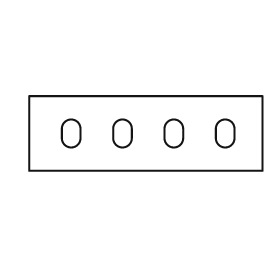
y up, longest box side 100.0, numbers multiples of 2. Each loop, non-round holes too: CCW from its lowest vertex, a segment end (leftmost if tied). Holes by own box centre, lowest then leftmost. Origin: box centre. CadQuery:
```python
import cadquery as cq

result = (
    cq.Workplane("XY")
    .moveTo(-50.0, -16.0)
    .lineTo(50.0, -16.0)
    .lineTo(50.0, 16.0)
    .lineTo(-50.0, 16.0)
    .close()
    .moveTo(-36.0, -2.0)
    .threePointArc((-32.0, -6.0), (-28.0, -2.0))
    .lineTo(-28.0, 2.0)
    .threePointArc((-32.0, 6.0), (-36.0, 2.0))
    .close()
    .moveTo(-14.0, -2.0)
    .threePointArc((-10.0, -6.0), (-6.0, -2.0))
    .lineTo(-6.0, 2.0)
    .threePointArc((-10.0, 6.0), (-14.0, 2.0))
    .close()
    .moveTo(8.0, -2.0)
    .threePointArc((12.0, -6.0), (16.0, -2.0))
    .lineTo(16.0, 2.0)
    .threePointArc((12.0, 6.0), (8.0, 2.0))
    .close()
    .moveTo(30.0, -2.0)
    .threePointArc((34.0, -6.0), (38.0, -2.0))
    .lineTo(38.0, 2.0)
    .threePointArc((34.0, 6.0), (30.0, 2.0))
    .close()
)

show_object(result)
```